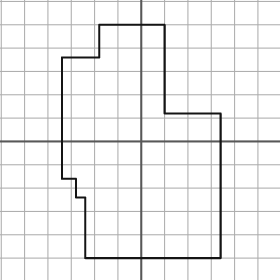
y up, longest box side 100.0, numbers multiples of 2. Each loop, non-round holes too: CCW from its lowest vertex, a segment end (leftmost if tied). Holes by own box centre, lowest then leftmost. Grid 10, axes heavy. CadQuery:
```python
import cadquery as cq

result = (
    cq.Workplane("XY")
    .moveTo(-24.0, -50.0)
    .lineTo(34.0, -50.0)
    .lineTo(34.0, 12.0)
    .lineTo(10.0, 12.0)
    .lineTo(10.0, 50.0)
    .lineTo(-18.0, 50.0)
    .lineTo(-18.0, 36.0)
    .lineTo(-34.0, 36.0)
    .lineTo(-34.0, -16.0)
    .lineTo(-28.0, -16.0)
    .lineTo(-28.0, -24.0)
    .lineTo(-24.0, -24.0)
    .close()
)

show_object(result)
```